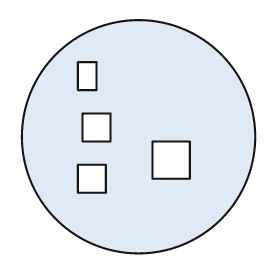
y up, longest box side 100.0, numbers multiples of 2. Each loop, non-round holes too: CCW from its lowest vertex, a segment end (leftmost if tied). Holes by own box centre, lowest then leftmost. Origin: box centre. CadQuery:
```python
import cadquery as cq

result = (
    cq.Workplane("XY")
    .moveTo(0.0, 0.0)
    .circle(50.0)
    .moveTo(-26.0, -24.0)
    .lineTo(-14.0, -24.0)
    .lineTo(-14.0, -12.0)
    .lineTo(-26.0, -12.0)
    .close()
    .moveTo(6.0, -18.0)
    .lineTo(22.0, -18.0)
    .lineTo(22.0, -2.0)
    .lineTo(6.0, -2.0)
    .close()
    .moveTo(-24.0, -2.0)
    .lineTo(-12.0, -2.0)
    .lineTo(-12.0, 10.0)
    .lineTo(-24.0, 10.0)
    .close()
    .moveTo(-26.0, 20.0)
    .lineTo(-18.0, 20.0)
    .lineTo(-18.0, 32.0)
    .lineTo(-26.0, 32.0)
    .close()
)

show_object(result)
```